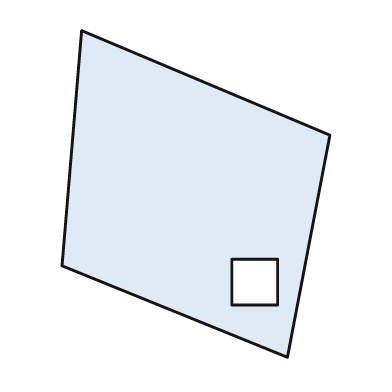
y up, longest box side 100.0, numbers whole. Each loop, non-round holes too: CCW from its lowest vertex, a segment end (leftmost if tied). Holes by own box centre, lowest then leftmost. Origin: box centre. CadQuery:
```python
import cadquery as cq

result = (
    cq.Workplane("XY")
    .moveTo(28.0, -50.0)
    .lineTo(41.0, 18.0)
    .lineTo(-35.0, 50.0)
    .lineTo(-41.0, -22.0)
    .close()
    .moveTo(11.0, -34.0)
    .lineTo(25.0, -34.0)
    .lineTo(25.0, -20.0)
    .lineTo(11.0, -20.0)
    .close()
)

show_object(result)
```